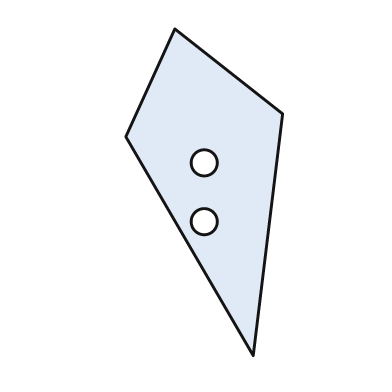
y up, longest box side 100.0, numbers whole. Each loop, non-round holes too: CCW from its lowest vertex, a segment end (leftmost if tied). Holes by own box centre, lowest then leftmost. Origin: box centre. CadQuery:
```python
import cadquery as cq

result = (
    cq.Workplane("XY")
    .moveTo(15.0, -50.0)
    .lineTo(24.0, 24.0)
    .lineTo(-9.0, 50.0)
    .lineTo(-24.0, 17.0)
    .close()
    .moveTo(0.0, -9.0)
    .circle(4.0)
    .moveTo(0.0, 9.0)
    .circle(4.0)
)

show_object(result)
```